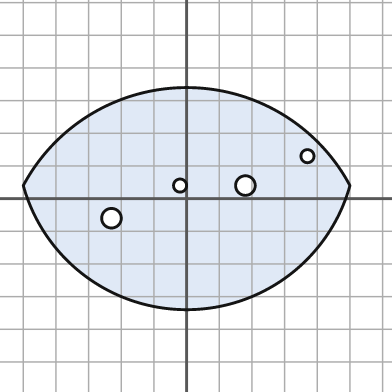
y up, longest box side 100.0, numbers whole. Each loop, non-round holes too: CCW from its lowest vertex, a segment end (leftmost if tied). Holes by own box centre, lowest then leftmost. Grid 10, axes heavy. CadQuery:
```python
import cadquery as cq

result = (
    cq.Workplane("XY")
    .moveTo(-50.0, 4.0)
    .threePointArc((0.0, -34.0), (50.0, 4.0))
    .threePointArc((0.0, 34.0), (-50.0, 4.0))
    .close()
    .moveTo(-23.0, -6.0)
    .circle(3.0)
    .moveTo(-2.0, 4.0)
    .circle(2.0)
    .moveTo(18.0, 4.0)
    .circle(3.0)
    .moveTo(37.0, 13.0)
    .circle(2.0)
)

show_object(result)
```